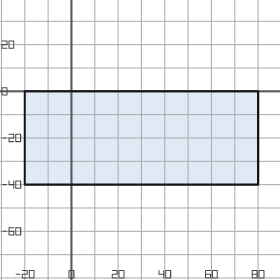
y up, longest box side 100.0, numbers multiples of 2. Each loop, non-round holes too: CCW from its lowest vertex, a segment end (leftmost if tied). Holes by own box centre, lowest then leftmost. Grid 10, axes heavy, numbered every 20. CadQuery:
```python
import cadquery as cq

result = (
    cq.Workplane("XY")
    .moveTo(-20.0, -40.0)
    .lineTo(80.0, -40.0)
    .lineTo(80.0, 0.0)
    .lineTo(-20.0, 0.0)
    .close()
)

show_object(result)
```